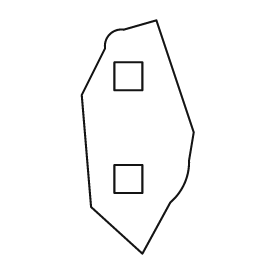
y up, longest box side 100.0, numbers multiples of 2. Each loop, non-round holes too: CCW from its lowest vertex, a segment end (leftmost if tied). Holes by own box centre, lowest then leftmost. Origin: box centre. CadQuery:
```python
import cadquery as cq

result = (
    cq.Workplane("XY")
    .moveTo(2.0, -50.0)
    .lineTo(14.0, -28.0)
    .threePointArc((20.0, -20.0), (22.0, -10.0))
    .lineTo(24.0, 2.0)
    .lineTo(8.0, 50.0)
    .lineTo(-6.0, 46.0)
    .threePointArc((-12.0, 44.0), (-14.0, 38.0))
    .lineTo(-24.0, 18.0)
    .lineTo(-20.0, -30.0)
    .close()
    .moveTo(-10.0, -24.0)
    .lineTo(2.0, -24.0)
    .lineTo(2.0, -12.0)
    .lineTo(-10.0, -12.0)
    .close()
    .moveTo(-10.0, 20.0)
    .lineTo(2.0, 20.0)
    .lineTo(2.0, 32.0)
    .lineTo(-10.0, 32.0)
    .close()
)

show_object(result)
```